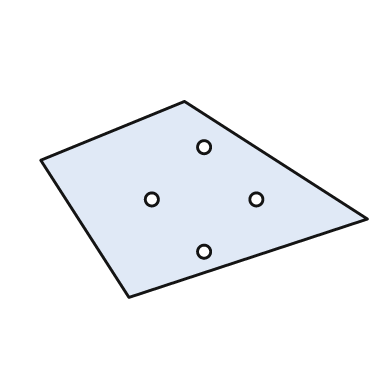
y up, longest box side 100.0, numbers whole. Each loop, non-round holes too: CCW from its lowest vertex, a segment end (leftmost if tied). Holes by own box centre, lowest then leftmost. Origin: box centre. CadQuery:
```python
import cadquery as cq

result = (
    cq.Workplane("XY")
    .moveTo(-23.0, -30.0)
    .lineTo(50.0, -6.0)
    .lineTo(-6.0, 30.0)
    .lineTo(-50.0, 12.0)
    .close()
    .moveTo(0.0, -16.0)
    .circle(2.0)
    .moveTo(-16.0, 0.0)
    .circle(2.0)
    .moveTo(16.0, 0.0)
    .circle(2.0)
    .moveTo(0.0, 16.0)
    .circle(2.0)
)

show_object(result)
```